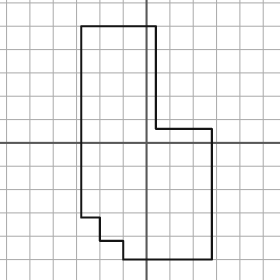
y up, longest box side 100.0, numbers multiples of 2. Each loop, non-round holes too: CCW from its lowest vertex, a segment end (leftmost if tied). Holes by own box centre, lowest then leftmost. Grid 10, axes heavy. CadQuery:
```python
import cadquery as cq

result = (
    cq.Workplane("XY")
    .moveTo(-10.0, -50.0)
    .lineTo(28.0, -50.0)
    .lineTo(28.0, 6.0)
    .lineTo(4.0, 6.0)
    .lineTo(4.0, 50.0)
    .lineTo(-28.0, 50.0)
    .lineTo(-28.0, -32.0)
    .lineTo(-20.0, -32.0)
    .lineTo(-20.0, -42.0)
    .lineTo(-10.0, -42.0)
    .close()
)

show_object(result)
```